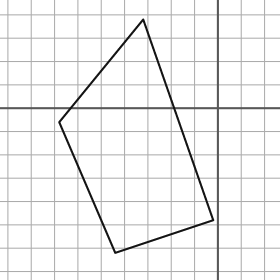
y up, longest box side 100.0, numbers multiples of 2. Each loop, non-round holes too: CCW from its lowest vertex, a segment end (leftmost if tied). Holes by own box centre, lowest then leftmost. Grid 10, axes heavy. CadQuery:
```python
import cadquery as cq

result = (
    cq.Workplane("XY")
    .moveTo(-44.0, -62.0)
    .lineTo(-2.0, -48.0)
    .lineTo(-32.0, 38.0)
    .lineTo(-68.0, -6.0)
    .close()
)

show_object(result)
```